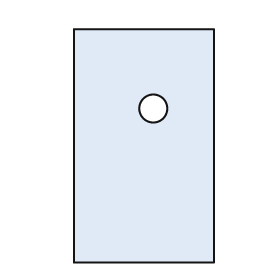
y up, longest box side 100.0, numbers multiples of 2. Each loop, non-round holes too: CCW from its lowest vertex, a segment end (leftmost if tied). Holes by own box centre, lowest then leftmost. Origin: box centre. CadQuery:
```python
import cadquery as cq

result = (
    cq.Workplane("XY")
    .moveTo(-30.0, -50.0)
    .lineTo(30.0, -50.0)
    .lineTo(30.0, 50.0)
    .lineTo(-30.0, 50.0)
    .close()
    .moveTo(4.0, 16.0)
    .circle(6.0)
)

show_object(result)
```